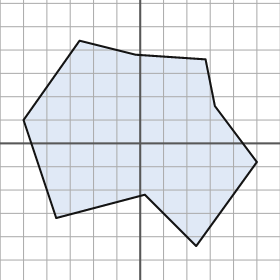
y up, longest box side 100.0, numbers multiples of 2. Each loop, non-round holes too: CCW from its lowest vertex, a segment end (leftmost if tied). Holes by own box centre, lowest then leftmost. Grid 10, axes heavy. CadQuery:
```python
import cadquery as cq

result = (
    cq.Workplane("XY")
    .moveTo(24.0, -44.0)
    .lineTo(50.0, -8.0)
    .lineTo(32.0, 16.0)
    .lineTo(28.0, 36.0)
    .lineTo(-2.0, 38.0)
    .lineTo(-26.0, 44.0)
    .lineTo(-50.0, 10.0)
    .lineTo(-36.0, -32.0)
    .lineTo(2.0, -22.0)
    .close()
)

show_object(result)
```